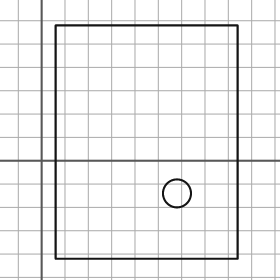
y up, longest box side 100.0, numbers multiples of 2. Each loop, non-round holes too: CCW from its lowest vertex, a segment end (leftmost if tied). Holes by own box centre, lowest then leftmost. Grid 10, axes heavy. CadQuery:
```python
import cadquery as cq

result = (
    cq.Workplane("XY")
    .moveTo(6.0, -42.0)
    .lineTo(84.0, -42.0)
    .lineTo(84.0, 58.0)
    .lineTo(6.0, 58.0)
    .close()
    .moveTo(58.0, -14.0)
    .circle(6.0)
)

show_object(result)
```